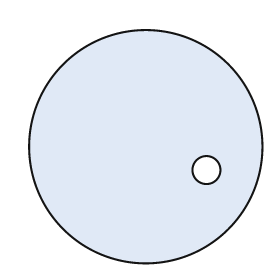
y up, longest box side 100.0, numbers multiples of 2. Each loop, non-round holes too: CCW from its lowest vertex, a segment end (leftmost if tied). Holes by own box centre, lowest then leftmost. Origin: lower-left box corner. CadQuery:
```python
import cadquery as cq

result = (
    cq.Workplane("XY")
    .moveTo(50.0, 50.0)
    .circle(50.0)
    .moveTo(76.0, 40.0)
    .circle(6.0)
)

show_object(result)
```